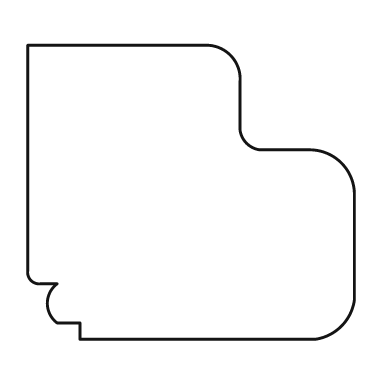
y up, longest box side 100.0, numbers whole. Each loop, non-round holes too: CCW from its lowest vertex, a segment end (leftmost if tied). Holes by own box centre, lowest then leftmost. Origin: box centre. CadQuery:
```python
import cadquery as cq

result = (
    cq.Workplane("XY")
    .moveTo(-34.0, -45.0)
    .lineTo(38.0, -45.0)
    .threePointArc((46.0, -41.0), (50.0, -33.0))
    .lineTo(50.0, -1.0)
    .threePointArc((46.0, 9.0), (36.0, 13.0))
    .lineTo(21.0, 13.0)
    .threePointArc((17.0, 15.0), (15.0, 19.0))
    .lineTo(15.0, 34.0)
    .threePointArc((12.0, 42.0), (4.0, 45.0))
    .lineTo(-50.0, 45.0)
    .lineTo(-50.0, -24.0)
    .threePointArc((-49.0, -27.0), (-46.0, -28.0))
    .lineTo(-41.0, -28.0)
    .threePointArc((-44.0, -34.0), (-41.0, -40.0))
    .lineTo(-34.0, -40.0)
    .close()
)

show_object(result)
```